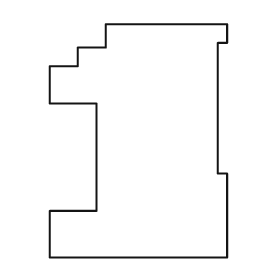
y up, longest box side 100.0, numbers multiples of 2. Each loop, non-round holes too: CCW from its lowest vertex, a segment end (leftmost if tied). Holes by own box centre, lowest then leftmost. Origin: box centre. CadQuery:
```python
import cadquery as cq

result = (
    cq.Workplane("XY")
    .moveTo(-38.0, -50.0)
    .lineTo(38.0, -50.0)
    .lineTo(38.0, -14.0)
    .lineTo(34.0, -14.0)
    .lineTo(34.0, 42.0)
    .lineTo(38.0, 42.0)
    .lineTo(38.0, 50.0)
    .lineTo(-14.0, 50.0)
    .lineTo(-14.0, 40.0)
    .lineTo(-26.0, 40.0)
    .lineTo(-26.0, 32.0)
    .lineTo(-38.0, 32.0)
    .lineTo(-38.0, 16.0)
    .lineTo(-18.0, 16.0)
    .lineTo(-18.0, -30.0)
    .lineTo(-38.0, -30.0)
    .close()
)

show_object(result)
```